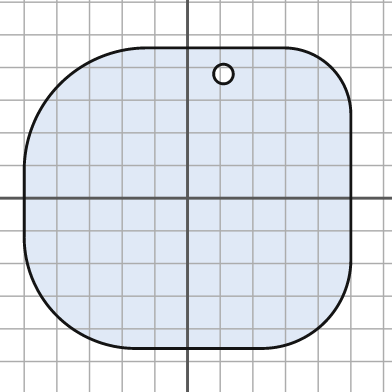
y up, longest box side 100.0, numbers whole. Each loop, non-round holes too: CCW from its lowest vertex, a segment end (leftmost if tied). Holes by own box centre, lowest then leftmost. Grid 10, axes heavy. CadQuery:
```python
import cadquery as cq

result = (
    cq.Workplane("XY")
    .moveTo(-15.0, -46.0)
    .lineTo(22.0, -46.0)
    .threePointArc((42.0, -38.0), (50.0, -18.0))
    .lineTo(50.0, 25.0)
    .threePointArc((44.0, 40.0), (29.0, 46.0))
    .lineTo(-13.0, 46.0)
    .threePointArc((-39.0, 35.0), (-50.0, 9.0))
    .lineTo(-50.0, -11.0)
    .threePointArc((-40.0, -36.0), (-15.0, -46.0))
    .close()
    .moveTo(11.0, 38.0)
    .circle(3.0)
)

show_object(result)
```